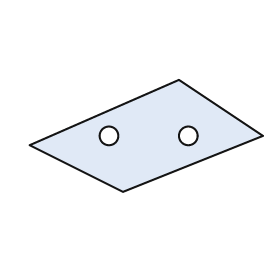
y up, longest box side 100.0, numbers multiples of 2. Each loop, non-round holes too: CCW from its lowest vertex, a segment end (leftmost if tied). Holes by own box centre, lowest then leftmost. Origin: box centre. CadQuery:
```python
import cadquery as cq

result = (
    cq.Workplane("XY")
    .moveTo(-10.0, -24.0)
    .lineTo(50.0, 0.0)
    .lineTo(14.0, 24.0)
    .lineTo(-50.0, -4.0)
    .close()
    .moveTo(-16.0, 0.0)
    .circle(4.0)
    .moveTo(18.0, 0.0)
    .circle(4.0)
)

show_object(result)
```